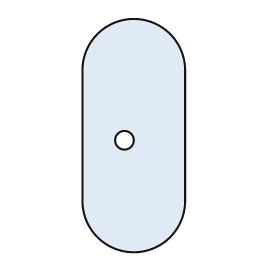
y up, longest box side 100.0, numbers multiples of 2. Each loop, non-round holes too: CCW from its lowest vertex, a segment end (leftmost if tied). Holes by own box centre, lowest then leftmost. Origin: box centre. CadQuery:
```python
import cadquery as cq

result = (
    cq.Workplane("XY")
    .moveTo(-22.0, -28.0)
    .threePointArc((0.0, -50.0), (22.0, -28.0))
    .lineTo(22.0, 28.0)
    .threePointArc((0.0, 50.0), (-22.0, 28.0))
    .close()
    .moveTo(-4.0, -2.0)
    .circle(4.0)
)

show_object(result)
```